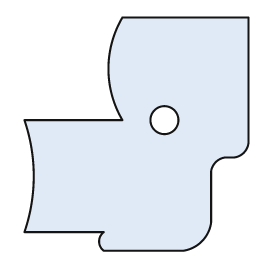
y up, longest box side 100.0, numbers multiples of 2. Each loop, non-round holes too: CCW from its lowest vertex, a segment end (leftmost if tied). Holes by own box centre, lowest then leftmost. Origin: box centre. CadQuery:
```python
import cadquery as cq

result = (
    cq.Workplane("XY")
    .moveTo(-14.0, -50.0)
    .lineTo(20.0, -50.0)
    .threePointArc((28.0, -46.0), (32.0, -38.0))
    .lineTo(32.0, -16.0)
    .threePointArc((34.0, -12.0), (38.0, -10.0))
    .lineTo(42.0, -10.0)
    .threePointArc((46.0, -8.0), (48.0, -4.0))
    .lineTo(48.0, 50.0)
    .lineTo(-6.0, 50.0)
    .threePointArc((-12.0, 28.0), (-6.0, 6.0))
    .lineTo(-48.0, 6.0)
    .threePointArc((-44.0, -18.0), (-48.0, -42.0))
    .lineTo(-14.0, -42.0)
    .threePointArc((-16.0, -46.0), (-14.0, -50.0))
    .close()
    .moveTo(12.0, 6.0)
    .circle(6.0)
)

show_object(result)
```